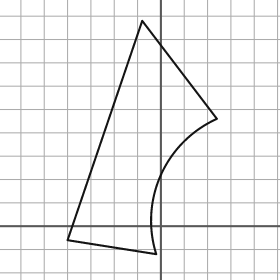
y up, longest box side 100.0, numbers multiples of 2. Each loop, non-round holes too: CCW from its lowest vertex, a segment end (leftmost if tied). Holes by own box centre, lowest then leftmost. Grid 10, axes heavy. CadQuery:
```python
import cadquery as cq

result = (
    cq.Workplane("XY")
    .moveTo(-2.0, -12.0)
    .threePointArc((0.0, 22.0), (24.0, 46.0))
    .lineTo(-8.0, 88.0)
    .lineTo(-40.0, -6.0)
    .close()
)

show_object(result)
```